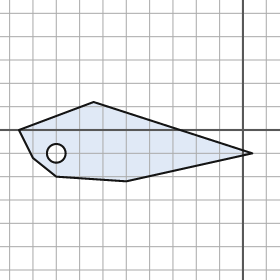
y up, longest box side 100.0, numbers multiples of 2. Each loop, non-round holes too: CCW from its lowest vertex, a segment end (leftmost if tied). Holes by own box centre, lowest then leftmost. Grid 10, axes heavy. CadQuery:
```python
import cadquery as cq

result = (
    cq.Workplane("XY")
    .moveTo(-50.0, -22.0)
    .lineTo(4.0, -10.0)
    .lineTo(-64.0, 12.0)
    .lineTo(-96.0, 0.0)
    .lineTo(-90.0, -12.0)
    .lineTo(-80.0, -20.0)
    .close()
    .moveTo(-80.0, -10.0)
    .circle(4.0)
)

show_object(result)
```